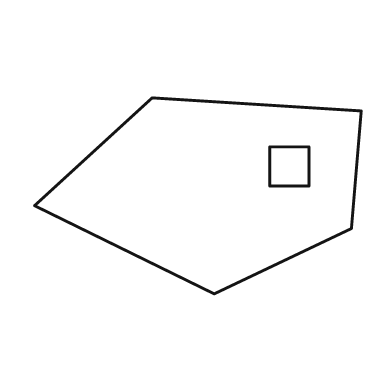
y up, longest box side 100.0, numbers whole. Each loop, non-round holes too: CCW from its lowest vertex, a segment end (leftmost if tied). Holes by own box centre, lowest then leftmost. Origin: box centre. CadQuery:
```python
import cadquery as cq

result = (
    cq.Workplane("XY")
    .moveTo(5.0, -30.0)
    .lineTo(47.0, -10.0)
    .lineTo(50.0, 26.0)
    .lineTo(-14.0, 30.0)
    .lineTo(-50.0, -3.0)
    .close()
    .moveTo(22.0, 3.0)
    .lineTo(34.0, 3.0)
    .lineTo(34.0, 15.0)
    .lineTo(22.0, 15.0)
    .close()
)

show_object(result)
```